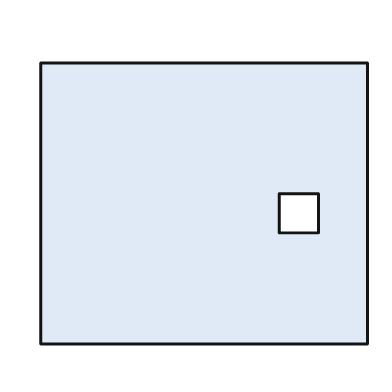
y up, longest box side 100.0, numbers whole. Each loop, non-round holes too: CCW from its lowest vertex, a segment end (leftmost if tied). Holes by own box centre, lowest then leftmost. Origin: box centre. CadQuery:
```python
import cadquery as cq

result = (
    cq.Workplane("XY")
    .moveTo(-50.0, -43.0)
    .lineTo(50.0, -43.0)
    .lineTo(50.0, 43.0)
    .lineTo(-50.0, 43.0)
    .close()
    .moveTo(23.0, -9.0)
    .lineTo(35.0, -9.0)
    .lineTo(35.0, 3.0)
    .lineTo(23.0, 3.0)
    .close()
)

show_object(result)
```